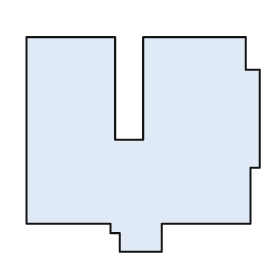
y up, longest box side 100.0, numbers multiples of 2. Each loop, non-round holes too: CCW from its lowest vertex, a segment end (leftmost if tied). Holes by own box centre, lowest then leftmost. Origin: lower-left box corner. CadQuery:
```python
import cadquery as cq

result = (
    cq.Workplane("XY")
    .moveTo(40.0, 0.0)
    .lineTo(58.0, 0.0)
    .lineTo(58.0, 12.0)
    .lineTo(96.0, 12.0)
    .lineTo(96.0, 36.0)
    .lineTo(100.0, 36.0)
    .lineTo(100.0, 78.0)
    .lineTo(94.0, 78.0)
    .lineTo(94.0, 92.0)
    .lineTo(50.0, 92.0)
    .lineTo(50.0, 48.0)
    .lineTo(38.0, 48.0)
    .lineTo(38.0, 92.0)
    .lineTo(0.0, 92.0)
    .lineTo(0.0, 12.0)
    .lineTo(36.0, 12.0)
    .lineTo(36.0, 8.0)
    .lineTo(40.0, 8.0)
    .close()
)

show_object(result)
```